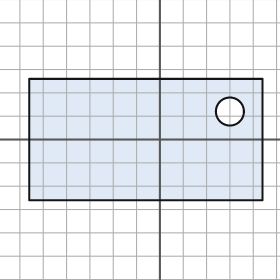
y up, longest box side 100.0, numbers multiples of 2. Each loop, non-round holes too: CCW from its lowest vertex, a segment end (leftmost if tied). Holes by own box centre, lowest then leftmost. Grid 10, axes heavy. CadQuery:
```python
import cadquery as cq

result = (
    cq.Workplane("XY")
    .moveTo(-56.0, -26.0)
    .lineTo(44.0, -26.0)
    .lineTo(44.0, 26.0)
    .lineTo(-56.0, 26.0)
    .close()
    .moveTo(30.0, 12.0)
    .circle(6.0)
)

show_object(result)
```